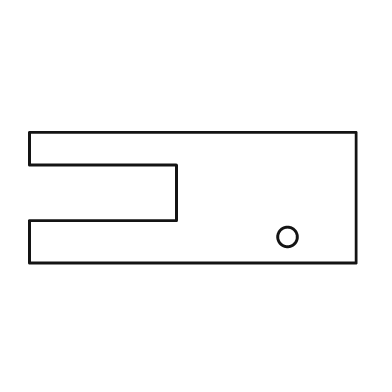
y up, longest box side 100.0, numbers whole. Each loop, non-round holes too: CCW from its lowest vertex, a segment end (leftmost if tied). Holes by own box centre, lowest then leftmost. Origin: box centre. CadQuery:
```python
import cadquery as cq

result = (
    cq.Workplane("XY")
    .moveTo(-50.0, -20.0)
    .lineTo(50.0, -20.0)
    .lineTo(50.0, 20.0)
    .lineTo(-50.0, 20.0)
    .lineTo(-50.0, 10.0)
    .lineTo(-5.0, 10.0)
    .lineTo(-5.0, -7.0)
    .lineTo(-50.0, -7.0)
    .close()
    .moveTo(29.0, -12.0)
    .circle(3.0)
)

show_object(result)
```